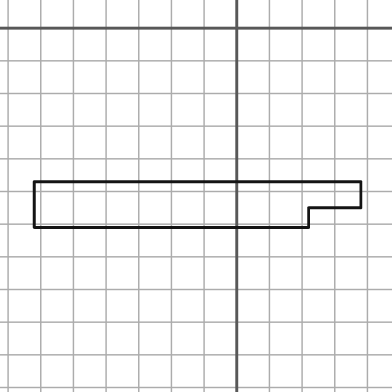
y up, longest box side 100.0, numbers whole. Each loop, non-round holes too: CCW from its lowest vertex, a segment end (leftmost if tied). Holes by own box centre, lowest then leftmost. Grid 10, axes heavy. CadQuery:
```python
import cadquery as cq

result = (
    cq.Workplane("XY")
    .moveTo(-62.0, -61.0)
    .lineTo(22.0, -61.0)
    .lineTo(22.0, -55.0)
    .lineTo(38.0, -55.0)
    .lineTo(38.0, -47.0)
    .lineTo(-62.0, -47.0)
    .close()
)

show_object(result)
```